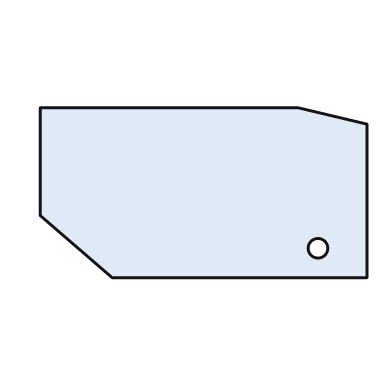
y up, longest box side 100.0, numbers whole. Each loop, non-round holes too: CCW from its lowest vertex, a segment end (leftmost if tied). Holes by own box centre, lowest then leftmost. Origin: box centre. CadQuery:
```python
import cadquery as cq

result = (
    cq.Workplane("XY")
    .moveTo(-28.0, -26.0)
    .lineTo(50.0, -26.0)
    .lineTo(50.0, 21.0)
    .lineTo(29.0, 26.0)
    .lineTo(-50.0, 26.0)
    .lineTo(-50.0, -7.0)
    .close()
    .moveTo(35.0, -17.0)
    .circle(3.0)
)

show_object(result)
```